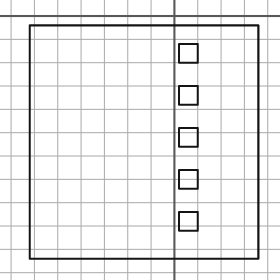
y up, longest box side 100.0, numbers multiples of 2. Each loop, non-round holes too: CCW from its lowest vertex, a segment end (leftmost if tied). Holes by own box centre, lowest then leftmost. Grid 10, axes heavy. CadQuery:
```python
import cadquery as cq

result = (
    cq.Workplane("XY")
    .moveTo(-62.0, -104.0)
    .lineTo(36.0, -104.0)
    .lineTo(36.0, -4.0)
    .lineTo(-62.0, -4.0)
    .close()
    .moveTo(2.0, -92.0)
    .lineTo(10.0, -92.0)
    .lineTo(10.0, -84.0)
    .lineTo(2.0, -84.0)
    .close()
    .moveTo(2.0, -74.0)
    .lineTo(10.0, -74.0)
    .lineTo(10.0, -66.0)
    .lineTo(2.0, -66.0)
    .close()
    .moveTo(2.0, -56.0)
    .lineTo(10.0, -56.0)
    .lineTo(10.0, -48.0)
    .lineTo(2.0, -48.0)
    .close()
    .moveTo(2.0, -38.0)
    .lineTo(10.0, -38.0)
    .lineTo(10.0, -30.0)
    .lineTo(2.0, -30.0)
    .close()
    .moveTo(2.0, -20.0)
    .lineTo(10.0, -20.0)
    .lineTo(10.0, -12.0)
    .lineTo(2.0, -12.0)
    .close()
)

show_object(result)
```